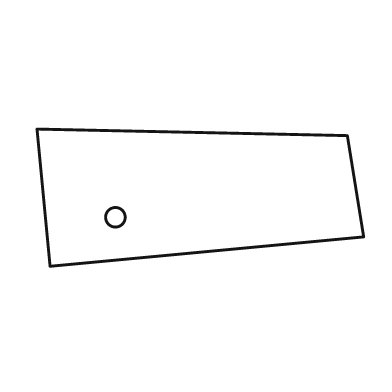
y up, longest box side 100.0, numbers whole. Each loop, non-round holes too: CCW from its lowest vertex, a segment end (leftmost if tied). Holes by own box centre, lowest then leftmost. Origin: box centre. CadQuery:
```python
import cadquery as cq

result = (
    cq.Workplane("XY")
    .moveTo(-46.0, -21.0)
    .lineTo(50.0, -12.0)
    .lineTo(45.0, 19.0)
    .lineTo(-50.0, 21.0)
    .close()
    .moveTo(-26.0, -6.0)
    .circle(3.0)
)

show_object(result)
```